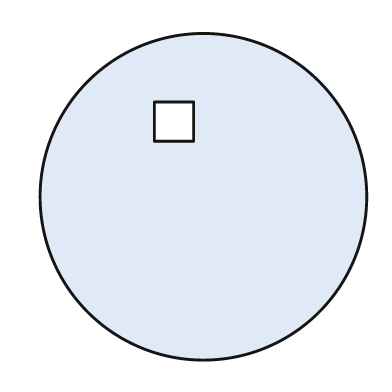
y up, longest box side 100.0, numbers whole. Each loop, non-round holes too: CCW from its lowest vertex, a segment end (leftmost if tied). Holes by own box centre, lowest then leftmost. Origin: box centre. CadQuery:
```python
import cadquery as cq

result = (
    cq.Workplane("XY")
    .moveTo(0.0, 0.0)
    .circle(50.0)
    .moveTo(-15.0, 17.0)
    .lineTo(-3.0, 17.0)
    .lineTo(-3.0, 29.0)
    .lineTo(-15.0, 29.0)
    .close()
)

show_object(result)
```